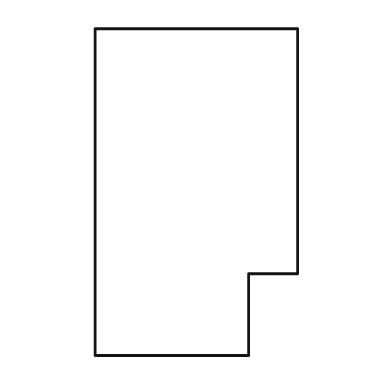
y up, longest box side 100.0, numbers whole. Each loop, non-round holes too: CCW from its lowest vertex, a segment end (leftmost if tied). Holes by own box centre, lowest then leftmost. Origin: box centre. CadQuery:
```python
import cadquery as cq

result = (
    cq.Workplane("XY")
    .moveTo(-31.0, -50.0)
    .lineTo(16.0, -50.0)
    .lineTo(16.0, -25.0)
    .lineTo(31.0, -25.0)
    .lineTo(31.0, 50.0)
    .lineTo(-31.0, 50.0)
    .close()
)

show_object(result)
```